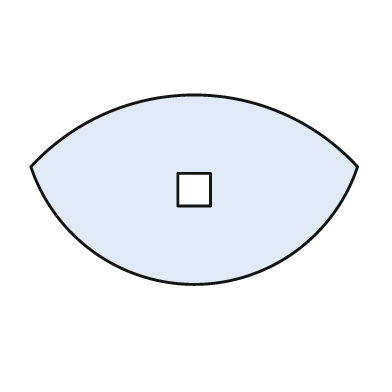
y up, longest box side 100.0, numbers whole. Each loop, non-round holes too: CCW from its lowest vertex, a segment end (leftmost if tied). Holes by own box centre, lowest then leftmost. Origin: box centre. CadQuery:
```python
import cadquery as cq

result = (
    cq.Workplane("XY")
    .moveTo(-50.0, 7.0)
    .threePointArc((0.0, -29.0), (50.0, 7.0))
    .threePointArc((0.0, 29.0), (-50.0, 7.0))
    .close()
    .moveTo(-5.0, -5.0)
    .lineTo(5.0, -5.0)
    .lineTo(5.0, 5.0)
    .lineTo(-5.0, 5.0)
    .close()
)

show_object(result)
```